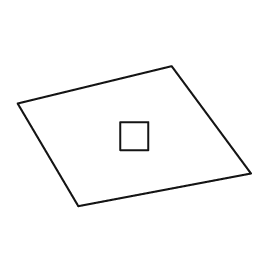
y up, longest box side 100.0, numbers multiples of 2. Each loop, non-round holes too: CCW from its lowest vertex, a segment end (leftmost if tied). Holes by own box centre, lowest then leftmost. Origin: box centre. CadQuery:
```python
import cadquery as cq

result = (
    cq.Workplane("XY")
    .moveTo(-24.0, -30.0)
    .lineTo(50.0, -16.0)
    .lineTo(16.0, 30.0)
    .lineTo(-50.0, 14.0)
    .close()
    .moveTo(-6.0, -6.0)
    .lineTo(6.0, -6.0)
    .lineTo(6.0, 6.0)
    .lineTo(-6.0, 6.0)
    .close()
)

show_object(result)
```